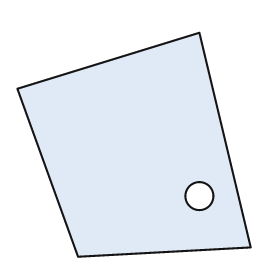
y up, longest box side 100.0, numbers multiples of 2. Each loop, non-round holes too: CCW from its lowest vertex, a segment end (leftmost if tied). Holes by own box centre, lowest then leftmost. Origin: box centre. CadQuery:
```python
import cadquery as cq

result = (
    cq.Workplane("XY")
    .moveTo(-24.0, -48.0)
    .lineTo(50.0, -44.0)
    .lineTo(28.0, 48.0)
    .lineTo(-50.0, 24.0)
    .close()
    .moveTo(28.0, -22.0)
    .circle(6.0)
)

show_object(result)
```